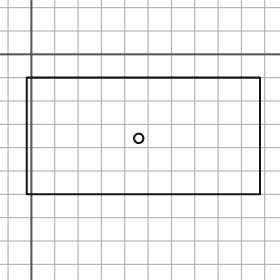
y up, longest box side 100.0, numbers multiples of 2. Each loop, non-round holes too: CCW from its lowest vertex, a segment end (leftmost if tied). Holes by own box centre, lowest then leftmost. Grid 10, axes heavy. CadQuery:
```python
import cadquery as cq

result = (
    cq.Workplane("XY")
    .moveTo(-2.0, -60.0)
    .lineTo(98.0, -60.0)
    .lineTo(98.0, -10.0)
    .lineTo(-2.0, -10.0)
    .close()
    .moveTo(46.0, -36.0)
    .circle(2.0)
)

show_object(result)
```